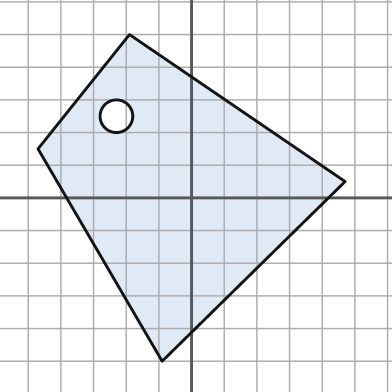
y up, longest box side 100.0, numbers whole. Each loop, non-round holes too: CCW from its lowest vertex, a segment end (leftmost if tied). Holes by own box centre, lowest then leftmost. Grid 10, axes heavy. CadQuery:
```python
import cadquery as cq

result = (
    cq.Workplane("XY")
    .moveTo(-9.0, -50.0)
    .lineTo(47.0, 5.0)
    .lineTo(-19.0, 50.0)
    .lineTo(-47.0, 15.0)
    .close()
    .moveTo(-23.0, 25.0)
    .circle(5.0)
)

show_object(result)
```